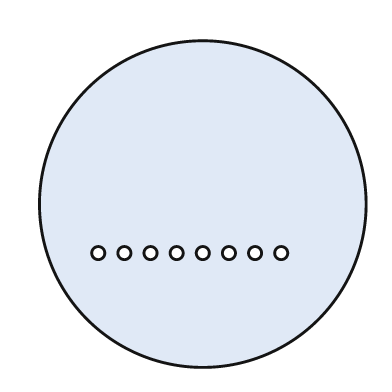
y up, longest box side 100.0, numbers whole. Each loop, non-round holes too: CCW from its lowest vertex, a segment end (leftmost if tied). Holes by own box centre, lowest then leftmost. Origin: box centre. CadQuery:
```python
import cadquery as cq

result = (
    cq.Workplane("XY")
    .moveTo(0.0, 0.0)
    .circle(50.0)
    .moveTo(-32.0, -15.0)
    .circle(2.0)
    .moveTo(-24.0, -15.0)
    .circle(2.0)
    .moveTo(-16.0, -15.0)
    .circle(2.0)
    .moveTo(-8.0, -15.0)
    .circle(2.0)
    .moveTo(0.0, -15.0)
    .circle(2.0)
    .moveTo(8.0, -15.0)
    .circle(2.0)
    .moveTo(16.0, -15.0)
    .circle(2.0)
    .moveTo(24.0, -15.0)
    .circle(2.0)
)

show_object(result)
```